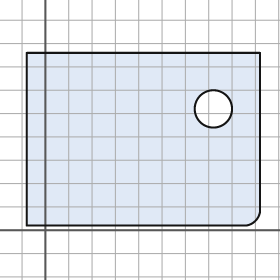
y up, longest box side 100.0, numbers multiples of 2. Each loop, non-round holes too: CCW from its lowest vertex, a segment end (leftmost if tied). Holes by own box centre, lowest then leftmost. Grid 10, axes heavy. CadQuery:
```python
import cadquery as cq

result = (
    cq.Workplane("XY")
    .moveTo(-8.0, 2.0)
    .lineTo(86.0, 2.0)
    .threePointArc((90.0, 4.0), (92.0, 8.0))
    .lineTo(92.0, 76.0)
    .lineTo(-8.0, 76.0)
    .close()
    .moveTo(72.0, 52.0)
    .circle(8.0)
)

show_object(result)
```